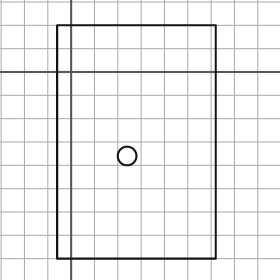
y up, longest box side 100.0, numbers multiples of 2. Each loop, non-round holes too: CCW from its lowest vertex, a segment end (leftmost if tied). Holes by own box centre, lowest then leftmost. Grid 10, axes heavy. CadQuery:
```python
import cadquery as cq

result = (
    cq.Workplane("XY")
    .moveTo(-6.0, -80.0)
    .lineTo(62.0, -80.0)
    .lineTo(62.0, 20.0)
    .lineTo(-6.0, 20.0)
    .close()
    .moveTo(24.0, -36.0)
    .circle(4.0)
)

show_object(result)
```